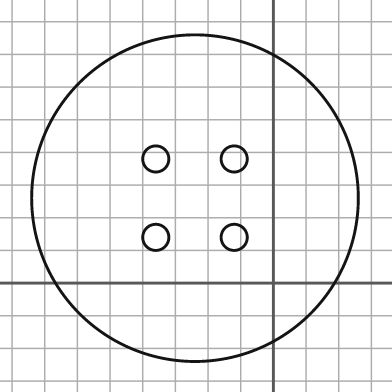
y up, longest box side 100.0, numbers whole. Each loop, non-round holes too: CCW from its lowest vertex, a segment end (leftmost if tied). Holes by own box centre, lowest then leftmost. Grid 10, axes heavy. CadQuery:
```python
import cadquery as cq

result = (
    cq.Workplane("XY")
    .moveTo(-24.0, 26.0)
    .circle(50.0)
    .moveTo(-36.0, 14.0)
    .circle(4.0)
    .moveTo(-12.0, 14.0)
    .circle(4.0)
    .moveTo(-36.0, 38.0)
    .circle(4.0)
    .moveTo(-12.0, 38.0)
    .circle(4.0)
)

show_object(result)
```